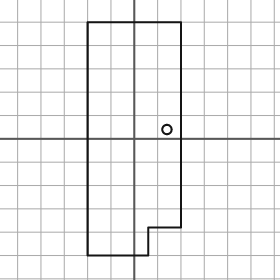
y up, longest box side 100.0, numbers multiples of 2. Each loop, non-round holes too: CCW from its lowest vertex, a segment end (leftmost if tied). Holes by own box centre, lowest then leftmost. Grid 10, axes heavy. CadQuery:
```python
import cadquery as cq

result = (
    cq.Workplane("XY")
    .moveTo(-20.0, -50.0)
    .lineTo(6.0, -50.0)
    .lineTo(6.0, -38.0)
    .lineTo(20.0, -38.0)
    .lineTo(20.0, 50.0)
    .lineTo(-20.0, 50.0)
    .close()
    .moveTo(14.0, 4.0)
    .circle(2.0)
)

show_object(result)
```